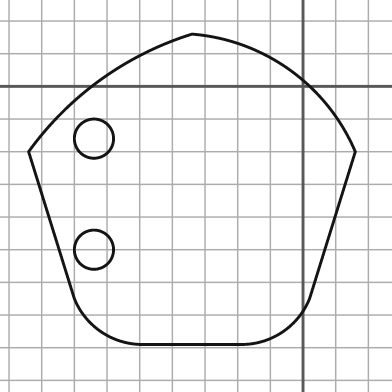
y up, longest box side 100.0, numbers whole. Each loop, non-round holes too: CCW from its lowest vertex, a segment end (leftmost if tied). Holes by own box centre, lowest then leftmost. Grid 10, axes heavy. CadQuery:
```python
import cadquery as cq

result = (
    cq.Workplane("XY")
    .moveTo(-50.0, -79.0)
    .lineTo(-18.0, -79.0)
    .threePointArc((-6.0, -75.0), (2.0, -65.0))
    .lineTo(16.0, -20.0)
    .threePointArc((-4.0, 5.0), (-34.0, 16.0))
    .threePointArc((-62.0, 2.0), (-84.0, -20.0))
    .lineTo(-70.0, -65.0)
    .threePointArc((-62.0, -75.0), (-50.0, -79.0))
    .close()
    .moveTo(-64.0, -50.0)
    .circle(6.0)
    .moveTo(-64.0, -16.0)
    .circle(6.0)
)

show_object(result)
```